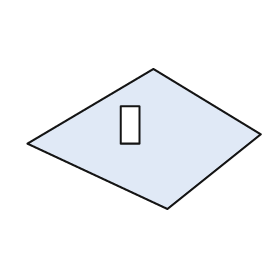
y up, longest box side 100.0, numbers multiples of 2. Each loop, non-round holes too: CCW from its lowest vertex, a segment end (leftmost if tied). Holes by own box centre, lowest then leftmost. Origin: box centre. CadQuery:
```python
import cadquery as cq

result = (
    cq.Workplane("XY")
    .moveTo(10.0, -30.0)
    .lineTo(50.0, 2.0)
    .lineTo(4.0, 30.0)
    .lineTo(-50.0, -2.0)
    .close()
    .moveTo(-10.0, -2.0)
    .lineTo(-2.0, -2.0)
    .lineTo(-2.0, 14.0)
    .lineTo(-10.0, 14.0)
    .close()
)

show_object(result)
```